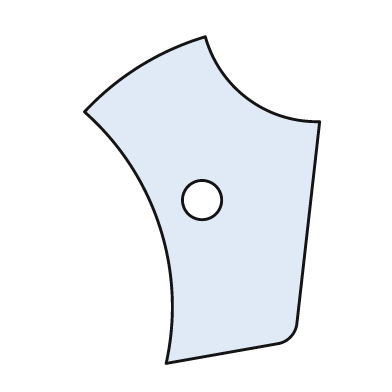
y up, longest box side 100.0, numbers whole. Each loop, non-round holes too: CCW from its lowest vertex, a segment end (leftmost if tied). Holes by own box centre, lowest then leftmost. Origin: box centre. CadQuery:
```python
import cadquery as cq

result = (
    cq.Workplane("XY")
    .moveTo(-11.0, -50.0)
    .lineTo(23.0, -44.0)
    .threePointArc((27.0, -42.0), (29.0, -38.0))
    .lineTo(36.0, 24.0)
    .threePointArc((14.0, 31.0), (1.0, 50.0))
    .threePointArc((-19.0, 41.0), (-36.0, 27.0))
    .threePointArc((-13.0, -8.0), (-11.0, -50.0))
    .close()
    .moveTo(0.0, 0.0)
    .circle(6.0)
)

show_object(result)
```